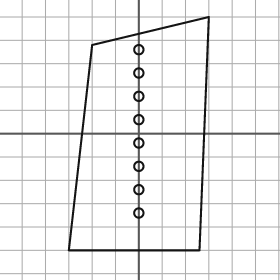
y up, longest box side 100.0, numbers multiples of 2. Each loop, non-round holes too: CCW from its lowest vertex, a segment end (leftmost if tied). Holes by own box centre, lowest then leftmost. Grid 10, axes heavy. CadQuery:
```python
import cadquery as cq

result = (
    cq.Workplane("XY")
    .moveTo(-30.0, -50.0)
    .lineTo(26.0, -50.0)
    .lineTo(30.0, 50.0)
    .lineTo(-20.0, 38.0)
    .close()
    .moveTo(0.0, -34.0)
    .circle(2.0)
    .moveTo(0.0, -24.0)
    .circle(2.0)
    .moveTo(0.0, -14.0)
    .circle(2.0)
    .moveTo(0.0, -4.0)
    .circle(2.0)
    .moveTo(0.0, 6.0)
    .circle(2.0)
    .moveTo(0.0, 16.0)
    .circle(2.0)
    .moveTo(0.0, 26.0)
    .circle(2.0)
    .moveTo(0.0, 36.0)
    .circle(2.0)
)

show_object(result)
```